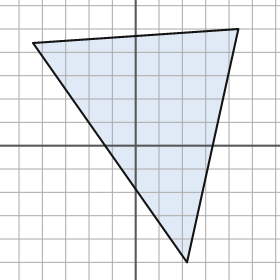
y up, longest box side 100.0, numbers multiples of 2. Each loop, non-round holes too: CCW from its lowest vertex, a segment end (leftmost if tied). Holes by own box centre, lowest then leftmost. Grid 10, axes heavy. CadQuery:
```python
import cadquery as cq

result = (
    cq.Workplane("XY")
    .moveTo(22.0, -50.0)
    .lineTo(44.0, 50.0)
    .lineTo(-44.0, 44.0)
    .close()
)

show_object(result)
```